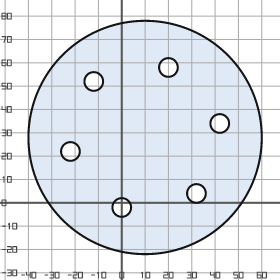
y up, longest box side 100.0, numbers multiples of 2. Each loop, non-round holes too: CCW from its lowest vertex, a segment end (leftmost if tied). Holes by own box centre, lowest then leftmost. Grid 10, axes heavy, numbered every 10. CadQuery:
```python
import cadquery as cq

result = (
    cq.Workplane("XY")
    .moveTo(10.0, 28.0)
    .circle(50.0)
    .moveTo(0.0, -2.0)
    .circle(4.0)
    .moveTo(32.0, 4.0)
    .circle(4.0)
    .moveTo(-22.0, 22.0)
    .circle(4.0)
    .moveTo(42.0, 34.0)
    .circle(4.0)
    .moveTo(-12.0, 52.0)
    .circle(4.0)
    .moveTo(20.0, 58.0)
    .circle(4.0)
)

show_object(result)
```